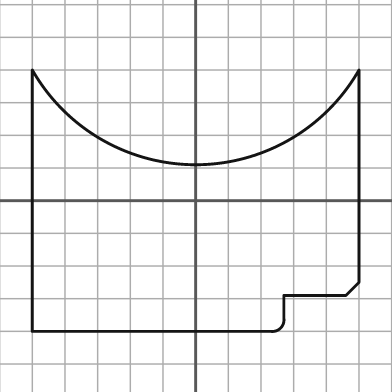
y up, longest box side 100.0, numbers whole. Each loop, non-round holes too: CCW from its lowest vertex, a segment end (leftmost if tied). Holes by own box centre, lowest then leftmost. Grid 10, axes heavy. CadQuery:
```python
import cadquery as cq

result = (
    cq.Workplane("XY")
    .moveTo(-50.0, -40.0)
    .lineTo(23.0, -40.0)
    .threePointArc((26.0, -39.0), (27.0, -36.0))
    .lineTo(27.0, -29.0)
    .lineTo(46.0, -29.0)
    .lineTo(50.0, -25.0)
    .lineTo(50.0, 40.0)
    .threePointArc((0.0, 11.0), (-50.0, 40.0))
    .close()
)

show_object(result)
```